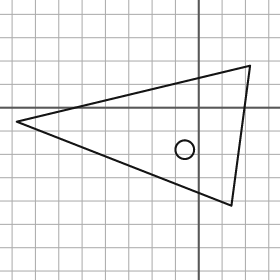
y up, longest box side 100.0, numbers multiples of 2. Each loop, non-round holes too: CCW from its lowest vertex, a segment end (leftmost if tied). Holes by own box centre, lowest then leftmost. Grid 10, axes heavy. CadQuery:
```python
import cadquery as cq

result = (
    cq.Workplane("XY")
    .moveTo(14.0, -42.0)
    .lineTo(22.0, 18.0)
    .lineTo(-78.0, -6.0)
    .close()
    .moveTo(-6.0, -18.0)
    .circle(4.0)
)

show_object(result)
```